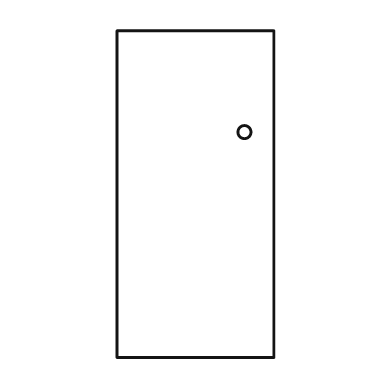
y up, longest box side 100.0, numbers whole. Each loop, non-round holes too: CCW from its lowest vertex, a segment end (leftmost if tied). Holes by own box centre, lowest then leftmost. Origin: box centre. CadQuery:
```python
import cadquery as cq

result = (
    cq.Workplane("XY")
    .moveTo(-24.0, -50.0)
    .lineTo(24.0, -50.0)
    .lineTo(24.0, 50.0)
    .lineTo(-24.0, 50.0)
    .close()
    .moveTo(15.0, 19.0)
    .circle(2.0)
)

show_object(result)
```